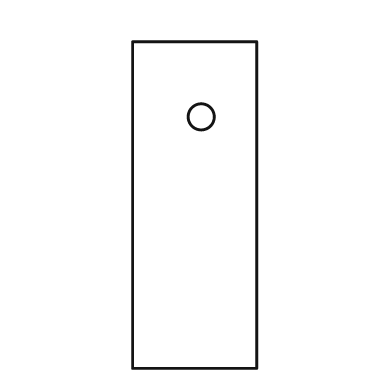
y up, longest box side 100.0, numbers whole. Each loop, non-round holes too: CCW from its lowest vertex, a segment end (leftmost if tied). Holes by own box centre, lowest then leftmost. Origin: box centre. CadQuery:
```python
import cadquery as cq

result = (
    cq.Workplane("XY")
    .moveTo(-19.0, -50.0)
    .lineTo(19.0, -50.0)
    .lineTo(19.0, 50.0)
    .lineTo(-19.0, 50.0)
    .close()
    .moveTo(2.0, 27.0)
    .circle(4.0)
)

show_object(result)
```